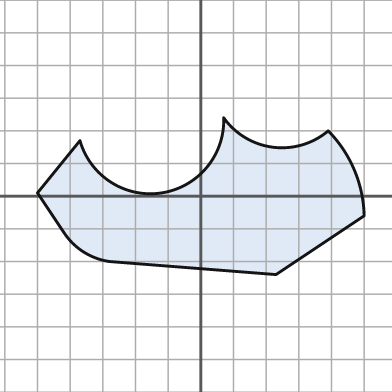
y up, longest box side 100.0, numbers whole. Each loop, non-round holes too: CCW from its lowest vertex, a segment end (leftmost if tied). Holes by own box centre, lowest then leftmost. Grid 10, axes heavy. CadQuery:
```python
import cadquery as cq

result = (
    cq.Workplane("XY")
    .moveTo(23.0, -24.0)
    .lineTo(50.0, -6.0)
    .threePointArc((47.0, 8.0), (39.0, 20.0))
    .threePointArc((22.0, 15.0), (7.0, 24.0))
    .threePointArc((-12.0, 1.0), (-37.0, 17.0))
    .lineTo(-50.0, 1.0)
    .lineTo(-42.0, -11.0)
    .threePointArc((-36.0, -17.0), (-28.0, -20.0))
    .close()
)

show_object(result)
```